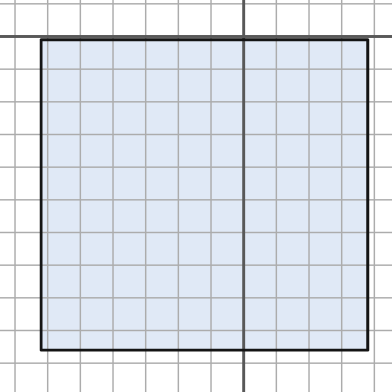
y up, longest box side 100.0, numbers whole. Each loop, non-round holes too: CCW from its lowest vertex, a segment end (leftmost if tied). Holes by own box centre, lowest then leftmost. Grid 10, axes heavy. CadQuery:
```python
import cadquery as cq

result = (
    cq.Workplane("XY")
    .moveTo(-62.0, -96.0)
    .lineTo(38.0, -96.0)
    .lineTo(38.0, -1.0)
    .lineTo(-62.0, -1.0)
    .close()
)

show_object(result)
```